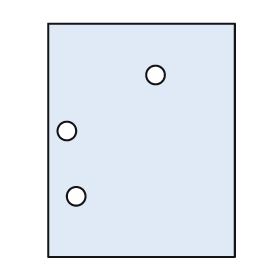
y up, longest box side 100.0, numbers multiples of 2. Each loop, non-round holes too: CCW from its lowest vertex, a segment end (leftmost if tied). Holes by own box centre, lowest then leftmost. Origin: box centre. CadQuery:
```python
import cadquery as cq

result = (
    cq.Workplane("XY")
    .moveTo(-40.0, -50.0)
    .lineTo(40.0, -50.0)
    .lineTo(40.0, 50.0)
    .lineTo(-40.0, 50.0)
    .close()
    .moveTo(-28.0, -24.0)
    .circle(4.0)
    .moveTo(-32.0, 4.0)
    .circle(4.0)
    .moveTo(6.0, 28.0)
    .circle(4.0)
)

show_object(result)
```